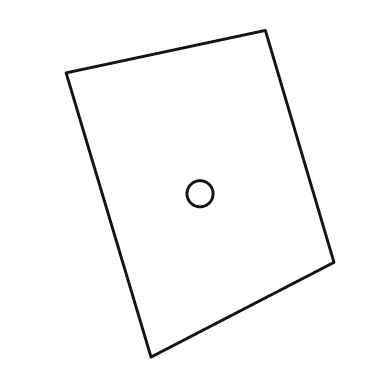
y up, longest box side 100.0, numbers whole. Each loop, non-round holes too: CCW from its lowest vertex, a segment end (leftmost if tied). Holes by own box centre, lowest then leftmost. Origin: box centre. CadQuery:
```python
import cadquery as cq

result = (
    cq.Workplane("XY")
    .moveTo(-15.0, -50.0)
    .lineTo(41.0, -21.0)
    .lineTo(20.0, 50.0)
    .lineTo(-41.0, 37.0)
    .close()
    .moveTo(0.0, 0.0)
    .circle(4.0)
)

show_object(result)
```